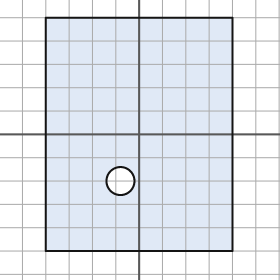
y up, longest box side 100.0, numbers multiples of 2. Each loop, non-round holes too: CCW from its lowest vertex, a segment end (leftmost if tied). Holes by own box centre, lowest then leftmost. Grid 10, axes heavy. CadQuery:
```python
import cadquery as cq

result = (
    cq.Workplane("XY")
    .moveTo(-40.0, -50.0)
    .lineTo(40.0, -50.0)
    .lineTo(40.0, 50.0)
    .lineTo(-40.0, 50.0)
    .close()
    .moveTo(-8.0, -20.0)
    .circle(6.0)
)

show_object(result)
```